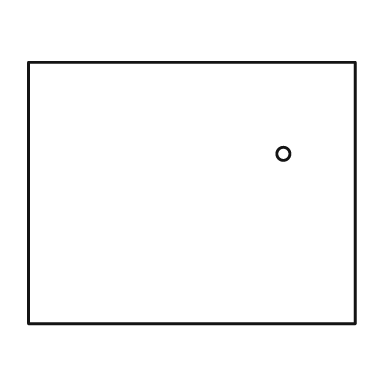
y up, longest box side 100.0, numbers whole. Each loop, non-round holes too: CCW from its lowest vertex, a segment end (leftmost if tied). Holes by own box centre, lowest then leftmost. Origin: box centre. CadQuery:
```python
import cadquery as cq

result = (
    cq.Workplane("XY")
    .moveTo(-50.0, -40.0)
    .lineTo(50.0, -40.0)
    .lineTo(50.0, 40.0)
    .lineTo(-50.0, 40.0)
    .close()
    .moveTo(28.0, 12.0)
    .circle(2.0)
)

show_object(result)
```